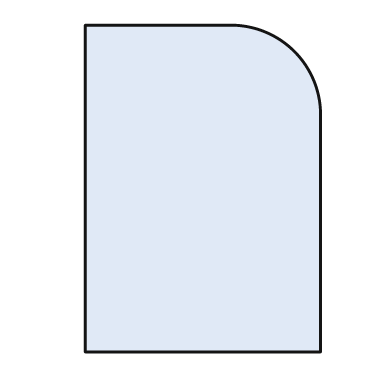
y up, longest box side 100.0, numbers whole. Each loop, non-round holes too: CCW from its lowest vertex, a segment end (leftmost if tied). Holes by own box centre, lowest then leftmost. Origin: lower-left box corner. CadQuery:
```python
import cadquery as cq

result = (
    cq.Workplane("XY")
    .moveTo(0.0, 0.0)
    .lineTo(72.0, 0.0)
    .lineTo(72.0, 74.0)
    .threePointArc((64.0, 92.0), (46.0, 100.0))
    .lineTo(0.0, 100.0)
    .close()
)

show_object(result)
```